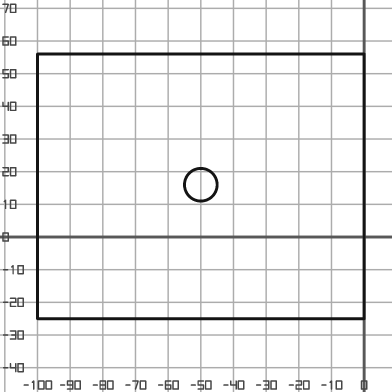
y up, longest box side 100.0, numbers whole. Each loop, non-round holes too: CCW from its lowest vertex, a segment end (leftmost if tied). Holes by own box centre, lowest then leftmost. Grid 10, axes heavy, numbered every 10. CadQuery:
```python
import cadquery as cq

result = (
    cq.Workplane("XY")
    .moveTo(-100.0, -25.0)
    .lineTo(0.0, -25.0)
    .lineTo(0.0, 56.0)
    .lineTo(-100.0, 56.0)
    .close()
    .moveTo(-50.0, 16.0)
    .circle(5.0)
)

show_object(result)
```